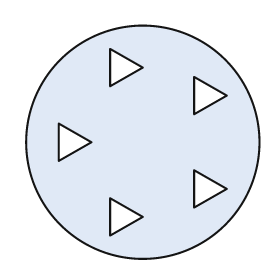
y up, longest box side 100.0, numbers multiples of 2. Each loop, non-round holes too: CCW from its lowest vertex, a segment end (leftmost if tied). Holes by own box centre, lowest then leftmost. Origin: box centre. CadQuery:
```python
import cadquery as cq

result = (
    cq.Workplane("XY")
    .moveTo(0.0, 0.0)
    .circle(50.0)
    .moveTo(-14.0, -40.0)
    .lineTo(0.0, -32.0)
    .lineTo(-14.0, -24.0)
    .close()
    .moveTo(22.0, -28.0)
    .lineTo(36.0, -20.0)
    .lineTo(22.0, -12.0)
    .close()
    .moveTo(-36.0, -8.0)
    .lineTo(-22.0, 0.0)
    .lineTo(-36.0, 8.0)
    .close()
    .moveTo(22.0, 12.0)
    .lineTo(36.0, 20.0)
    .lineTo(22.0, 28.0)
    .close()
    .moveTo(-14.0, 24.0)
    .lineTo(0.0, 32.0)
    .lineTo(-14.0, 40.0)
    .close()
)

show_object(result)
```